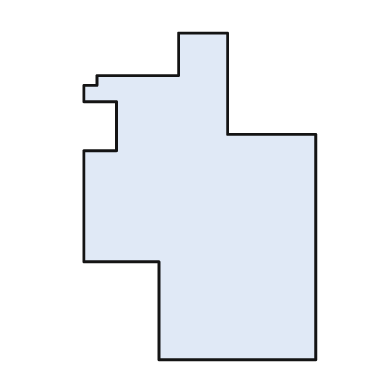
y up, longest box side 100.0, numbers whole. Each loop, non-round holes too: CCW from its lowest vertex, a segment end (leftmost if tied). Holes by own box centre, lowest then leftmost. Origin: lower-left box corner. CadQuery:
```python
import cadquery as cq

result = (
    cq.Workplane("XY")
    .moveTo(23.0, 0.0)
    .lineTo(71.0, 0.0)
    .lineTo(71.0, 69.0)
    .lineTo(44.0, 69.0)
    .lineTo(44.0, 100.0)
    .lineTo(29.0, 100.0)
    .lineTo(29.0, 87.0)
    .lineTo(4.0, 87.0)
    .lineTo(4.0, 84.0)
    .lineTo(0.0, 84.0)
    .lineTo(0.0, 79.0)
    .lineTo(10.0, 79.0)
    .lineTo(10.0, 64.0)
    .lineTo(0.0, 64.0)
    .lineTo(0.0, 30.0)
    .lineTo(23.0, 30.0)
    .close()
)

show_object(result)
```